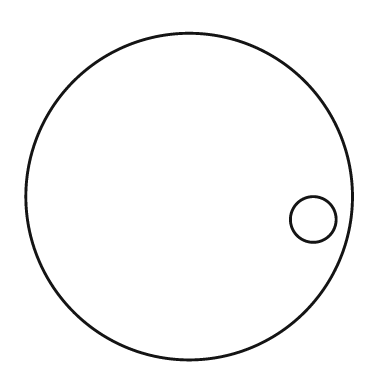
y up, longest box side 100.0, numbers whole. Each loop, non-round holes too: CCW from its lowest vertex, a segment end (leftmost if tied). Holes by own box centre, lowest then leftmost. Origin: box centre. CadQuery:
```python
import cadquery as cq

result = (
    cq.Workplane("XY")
    .moveTo(0.0, 0.0)
    .circle(50.0)
    .moveTo(38.0, -7.0)
    .circle(7.0)
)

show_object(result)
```